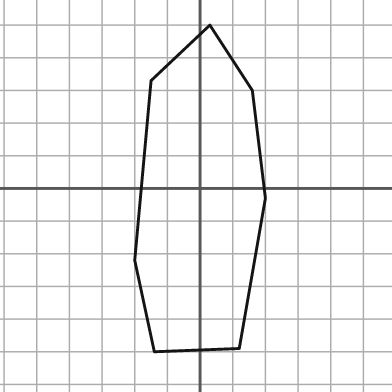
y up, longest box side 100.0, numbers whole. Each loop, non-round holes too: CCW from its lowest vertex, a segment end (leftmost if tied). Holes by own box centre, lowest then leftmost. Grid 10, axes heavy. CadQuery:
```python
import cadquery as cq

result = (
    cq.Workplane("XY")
    .moveTo(-14.0, -50.0)
    .lineTo(12.0, -49.0)
    .lineTo(20.0, -3.0)
    .lineTo(16.0, 30.0)
    .lineTo(3.0, 50.0)
    .lineTo(-15.0, 33.0)
    .lineTo(-20.0, -22.0)
    .close()
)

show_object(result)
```